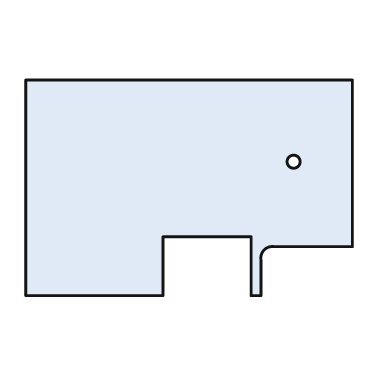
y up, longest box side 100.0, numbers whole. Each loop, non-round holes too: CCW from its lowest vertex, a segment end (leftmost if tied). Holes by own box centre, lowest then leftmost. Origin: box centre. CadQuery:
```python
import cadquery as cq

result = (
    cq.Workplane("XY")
    .moveTo(-50.0, -33.0)
    .lineTo(-8.0, -33.0)
    .lineTo(-8.0, -15.0)
    .lineTo(19.0, -15.0)
    .lineTo(19.0, -33.0)
    .lineTo(22.0, -33.0)
    .lineTo(22.0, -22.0)
    .threePointArc((23.0, -19.0), (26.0, -18.0))
    .lineTo(50.0, -18.0)
    .lineTo(50.0, 33.0)
    .lineTo(-50.0, 33.0)
    .close()
    .moveTo(32.0, 8.0)
    .circle(2.0)
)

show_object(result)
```